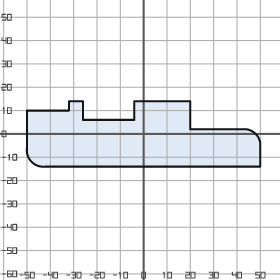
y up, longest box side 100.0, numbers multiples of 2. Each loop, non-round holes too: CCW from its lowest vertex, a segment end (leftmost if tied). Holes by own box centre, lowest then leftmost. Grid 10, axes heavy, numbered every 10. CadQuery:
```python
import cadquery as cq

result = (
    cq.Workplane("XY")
    .moveTo(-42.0, -14.0)
    .lineTo(50.0, -14.0)
    .lineTo(50.0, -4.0)
    .threePointArc((48.0, 0.0), (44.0, 2.0))
    .lineTo(20.0, 2.0)
    .lineTo(20.0, 14.0)
    .lineTo(-4.0, 14.0)
    .lineTo(-4.0, 6.0)
    .lineTo(-26.0, 6.0)
    .lineTo(-26.0, 14.0)
    .lineTo(-32.0, 14.0)
    .lineTo(-32.0, 10.0)
    .lineTo(-50.0, 10.0)
    .lineTo(-50.0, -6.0)
    .threePointArc((-48.0, -12.0), (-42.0, -14.0))
    .close()
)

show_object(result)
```